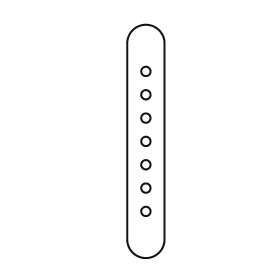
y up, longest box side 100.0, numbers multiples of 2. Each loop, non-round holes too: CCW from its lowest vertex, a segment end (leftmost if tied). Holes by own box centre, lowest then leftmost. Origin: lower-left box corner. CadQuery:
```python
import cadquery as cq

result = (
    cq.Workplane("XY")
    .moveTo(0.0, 8.0)
    .threePointArc((8.0, 0.0), (16.0, 8.0))
    .lineTo(16.0, 92.0)
    .threePointArc((8.0, 100.0), (0.0, 92.0))
    .close()
    .moveTo(8.0, 20.0)
    .circle(2.0)
    .moveTo(8.0, 30.0)
    .circle(2.0)
    .moveTo(8.0, 40.0)
    .circle(2.0)
    .moveTo(8.0, 50.0)
    .circle(2.0)
    .moveTo(8.0, 60.0)
    .circle(2.0)
    .moveTo(8.0, 70.0)
    .circle(2.0)
    .moveTo(8.0, 80.0)
    .circle(2.0)
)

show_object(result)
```